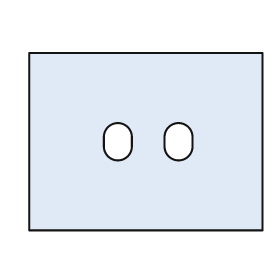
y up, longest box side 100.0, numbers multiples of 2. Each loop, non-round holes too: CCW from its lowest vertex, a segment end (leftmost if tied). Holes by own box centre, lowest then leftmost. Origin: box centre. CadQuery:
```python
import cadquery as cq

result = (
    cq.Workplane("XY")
    .moveTo(-50.0, -38.0)
    .lineTo(50.0, -38.0)
    .lineTo(50.0, 38.0)
    .lineTo(-50.0, 38.0)
    .close()
    .moveTo(-18.0, -2.0)
    .threePointArc((-12.0, -8.0), (-6.0, -2.0))
    .lineTo(-6.0, 2.0)
    .threePointArc((-12.0, 8.0), (-18.0, 2.0))
    .close()
    .moveTo(8.0, -2.0)
    .threePointArc((14.0, -8.0), (20.0, -2.0))
    .lineTo(20.0, 2.0)
    .threePointArc((14.0, 8.0), (8.0, 2.0))
    .close()
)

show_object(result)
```